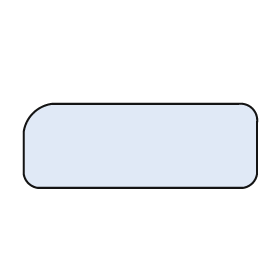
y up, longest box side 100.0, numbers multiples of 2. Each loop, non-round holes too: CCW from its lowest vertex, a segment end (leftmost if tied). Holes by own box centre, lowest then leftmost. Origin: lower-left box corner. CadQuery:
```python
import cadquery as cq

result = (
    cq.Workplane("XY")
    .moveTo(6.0, 0.0)
    .lineTo(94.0, 0.0)
    .threePointArc((98.0, 2.0), (100.0, 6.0))
    .lineTo(100.0, 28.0)
    .threePointArc((98.0, 34.0), (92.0, 36.0))
    .lineTo(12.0, 36.0)
    .threePointArc((4.0, 32.0), (0.0, 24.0))
    .lineTo(0.0, 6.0)
    .threePointArc((2.0, 2.0), (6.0, 0.0))
    .close()
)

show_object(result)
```